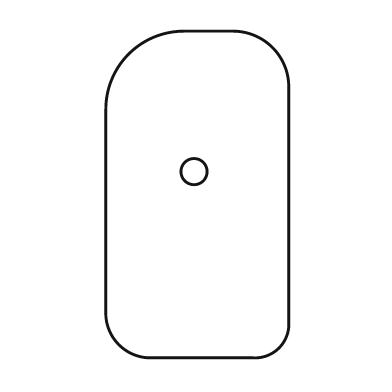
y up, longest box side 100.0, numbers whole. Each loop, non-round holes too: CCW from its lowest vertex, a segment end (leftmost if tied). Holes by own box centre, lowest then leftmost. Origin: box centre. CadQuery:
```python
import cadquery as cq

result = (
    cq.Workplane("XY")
    .moveTo(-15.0, -50.0)
    .lineTo(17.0, -50.0)
    .threePointArc((25.0, -47.0), (28.0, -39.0))
    .lineTo(28.0, 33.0)
    .threePointArc((23.0, 45.0), (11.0, 50.0))
    .lineTo(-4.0, 50.0)
    .threePointArc((-21.0, 43.0), (-28.0, 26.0))
    .lineTo(-28.0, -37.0)
    .threePointArc((-24.0, -46.0), (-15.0, -50.0))
    .close()
    .moveTo(-1.0, 7.0)
    .circle(4.0)
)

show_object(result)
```